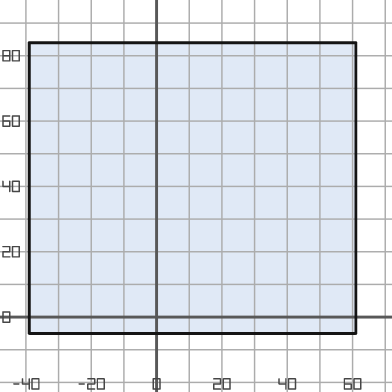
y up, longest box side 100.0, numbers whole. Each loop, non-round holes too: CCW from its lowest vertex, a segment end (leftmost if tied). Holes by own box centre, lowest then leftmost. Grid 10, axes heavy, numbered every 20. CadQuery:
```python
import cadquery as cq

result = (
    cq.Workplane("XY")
    .moveTo(-39.0, -5.0)
    .lineTo(61.0, -5.0)
    .lineTo(61.0, 84.0)
    .lineTo(-39.0, 84.0)
    .close()
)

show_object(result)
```